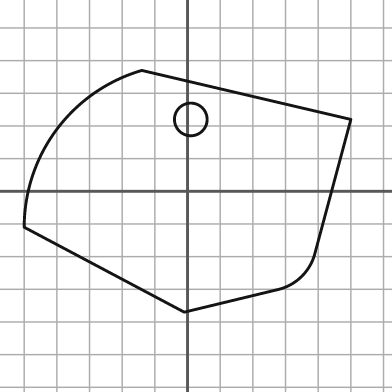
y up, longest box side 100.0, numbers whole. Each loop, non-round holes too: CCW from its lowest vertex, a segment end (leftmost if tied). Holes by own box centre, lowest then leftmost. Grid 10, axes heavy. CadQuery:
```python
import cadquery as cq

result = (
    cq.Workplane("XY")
    .moveTo(-1.0, -37.0)
    .lineTo(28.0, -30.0)
    .threePointArc((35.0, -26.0), (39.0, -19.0))
    .lineTo(50.0, 22.0)
    .lineTo(-14.0, 37.0)
    .threePointArc((-40.0, 19.0), (-50.0, -11.0))
    .close()
    .moveTo(1.0, 22.0)
    .circle(5.0)
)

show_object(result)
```